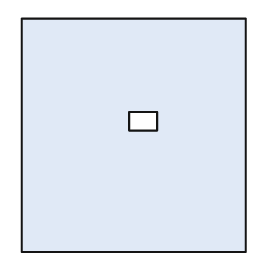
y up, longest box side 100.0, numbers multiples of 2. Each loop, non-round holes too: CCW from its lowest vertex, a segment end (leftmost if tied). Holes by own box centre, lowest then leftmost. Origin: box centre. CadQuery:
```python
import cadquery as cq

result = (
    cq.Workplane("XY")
    .moveTo(-48.0, -50.0)
    .lineTo(48.0, -50.0)
    .lineTo(48.0, 50.0)
    .lineTo(-48.0, 50.0)
    .close()
    .moveTo(-2.0, 2.0)
    .lineTo(10.0, 2.0)
    .lineTo(10.0, 10.0)
    .lineTo(-2.0, 10.0)
    .close()
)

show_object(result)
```